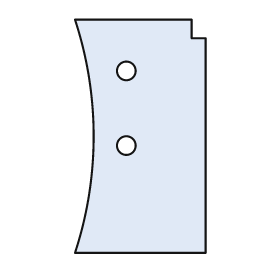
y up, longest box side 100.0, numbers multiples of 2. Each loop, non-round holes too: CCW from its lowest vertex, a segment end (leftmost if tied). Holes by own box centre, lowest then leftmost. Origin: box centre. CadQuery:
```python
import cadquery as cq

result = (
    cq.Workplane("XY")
    .moveTo(-28.0, -50.0)
    .lineTo(28.0, -50.0)
    .lineTo(28.0, 42.0)
    .lineTo(22.0, 42.0)
    .lineTo(22.0, 50.0)
    .lineTo(-28.0, 50.0)
    .threePointArc((-20.0, 0.0), (-28.0, -50.0))
    .close()
    .moveTo(-6.0, -4.0)
    .circle(4.0)
    .moveTo(-6.0, 28.0)
    .circle(4.0)
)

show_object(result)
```